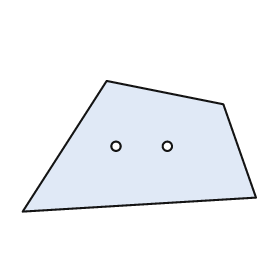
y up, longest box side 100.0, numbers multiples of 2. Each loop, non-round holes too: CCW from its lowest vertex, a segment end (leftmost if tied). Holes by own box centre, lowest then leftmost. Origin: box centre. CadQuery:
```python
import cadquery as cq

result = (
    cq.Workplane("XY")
    .moveTo(-50.0, -28.0)
    .lineTo(50.0, -22.0)
    .lineTo(36.0, 18.0)
    .lineTo(-14.0, 28.0)
    .close()
    .moveTo(-10.0, 0.0)
    .circle(2.0)
    .moveTo(12.0, 0.0)
    .circle(2.0)
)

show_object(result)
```